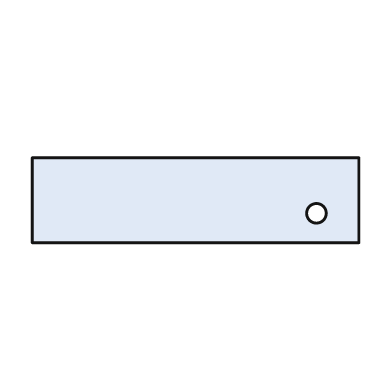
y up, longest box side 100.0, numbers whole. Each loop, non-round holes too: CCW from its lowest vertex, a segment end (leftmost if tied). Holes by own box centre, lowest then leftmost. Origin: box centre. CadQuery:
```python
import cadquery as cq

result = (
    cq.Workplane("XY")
    .moveTo(-50.0, -13.0)
    .lineTo(50.0, -13.0)
    .lineTo(50.0, 13.0)
    .lineTo(-50.0, 13.0)
    .close()
    .moveTo(37.0, -4.0)
    .circle(3.0)
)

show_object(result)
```